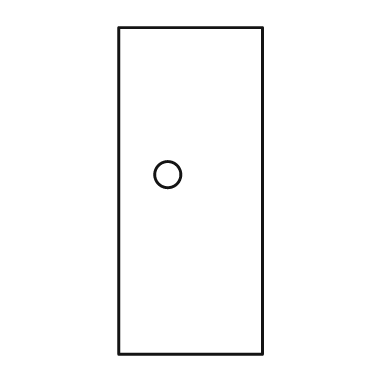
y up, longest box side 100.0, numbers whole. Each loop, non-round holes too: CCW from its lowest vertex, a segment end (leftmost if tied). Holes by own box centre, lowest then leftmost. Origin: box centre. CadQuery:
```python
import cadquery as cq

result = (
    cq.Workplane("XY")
    .moveTo(-22.0, -50.0)
    .lineTo(22.0, -50.0)
    .lineTo(22.0, 50.0)
    .lineTo(-22.0, 50.0)
    .close()
    .moveTo(-7.0, 5.0)
    .circle(4.0)
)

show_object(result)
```